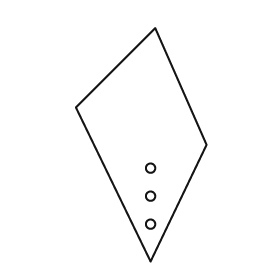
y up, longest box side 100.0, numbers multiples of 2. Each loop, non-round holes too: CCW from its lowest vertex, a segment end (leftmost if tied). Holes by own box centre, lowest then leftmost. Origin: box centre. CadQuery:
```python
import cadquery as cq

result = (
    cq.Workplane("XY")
    .moveTo(4.0, -50.0)
    .lineTo(28.0, 0.0)
    .lineTo(6.0, 50.0)
    .lineTo(-28.0, 16.0)
    .close()
    .moveTo(4.0, -34.0)
    .circle(2.0)
    .moveTo(4.0, -22.0)
    .circle(2.0)
    .moveTo(4.0, -10.0)
    .circle(2.0)
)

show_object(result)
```